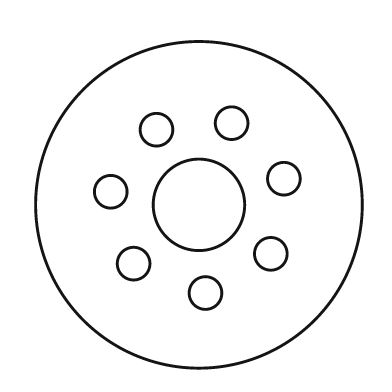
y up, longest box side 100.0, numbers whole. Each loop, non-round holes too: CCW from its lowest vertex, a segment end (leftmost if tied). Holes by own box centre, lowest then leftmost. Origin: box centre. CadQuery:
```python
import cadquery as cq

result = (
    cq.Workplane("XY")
    .moveTo(0.0, 0.0)
    .circle(50.0)
    .moveTo(2.0, -27.0)
    .circle(5.0)
    .moveTo(-20.0, -18.0)
    .circle(5.0)
    .moveTo(22.0, -15.0)
    .circle(5.0)
    .moveTo(0.0, 0.0)
    .circle(14.0)
    .moveTo(-27.0, 4.0)
    .circle(5.0)
    .moveTo(26.0, 8.0)
    .circle(5.0)
    .moveTo(-13.0, 23.0)
    .circle(5.0)
    .moveTo(10.0, 25.0)
    .circle(5.0)
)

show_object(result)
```